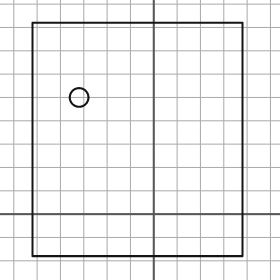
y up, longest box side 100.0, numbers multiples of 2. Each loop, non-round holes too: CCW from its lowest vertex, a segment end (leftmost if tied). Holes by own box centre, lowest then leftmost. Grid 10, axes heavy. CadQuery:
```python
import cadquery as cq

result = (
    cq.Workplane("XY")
    .moveTo(-52.0, -18.0)
    .lineTo(38.0, -18.0)
    .lineTo(38.0, 82.0)
    .lineTo(-52.0, 82.0)
    .close()
    .moveTo(-32.0, 50.0)
    .circle(4.0)
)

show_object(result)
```